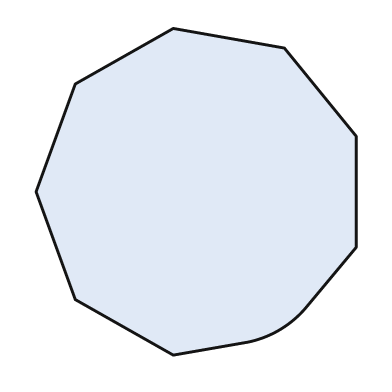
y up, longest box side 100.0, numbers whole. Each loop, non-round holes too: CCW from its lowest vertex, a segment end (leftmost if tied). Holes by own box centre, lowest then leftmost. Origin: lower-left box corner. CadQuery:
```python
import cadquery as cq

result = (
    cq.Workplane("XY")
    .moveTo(42.0, 0.0)
    .lineTo(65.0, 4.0)
    .threePointArc((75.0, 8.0), (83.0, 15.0))
    .lineTo(98.0, 33.0)
    .lineTo(98.0, 67.0)
    .lineTo(76.0, 94.0)
    .lineTo(42.0, 100.0)
    .lineTo(12.0, 83.0)
    .lineTo(0.0, 50.0)
    .lineTo(12.0, 17.0)
    .close()
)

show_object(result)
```